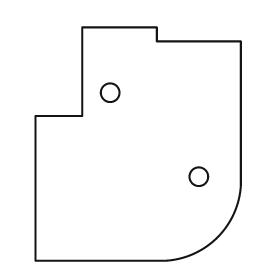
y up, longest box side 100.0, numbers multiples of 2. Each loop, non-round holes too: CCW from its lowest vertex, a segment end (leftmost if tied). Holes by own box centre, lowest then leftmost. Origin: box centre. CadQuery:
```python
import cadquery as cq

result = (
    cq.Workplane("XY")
    .moveTo(-44.0, -50.0)
    .lineTo(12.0, -50.0)
    .threePointArc((34.0, -40.0), (44.0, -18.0))
    .lineTo(44.0, 44.0)
    .lineTo(8.0, 44.0)
    .lineTo(8.0, 50.0)
    .lineTo(-24.0, 50.0)
    .lineTo(-24.0, 12.0)
    .lineTo(-44.0, 12.0)
    .close()
    .moveTo(26.0, -14.0)
    .circle(4.0)
    .moveTo(-12.0, 22.0)
    .circle(4.0)
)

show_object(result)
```